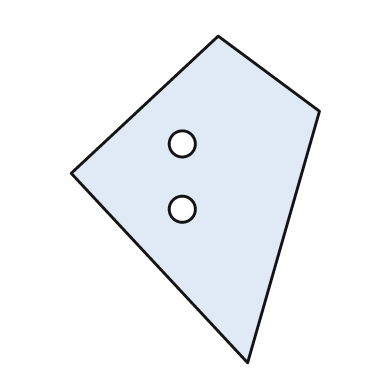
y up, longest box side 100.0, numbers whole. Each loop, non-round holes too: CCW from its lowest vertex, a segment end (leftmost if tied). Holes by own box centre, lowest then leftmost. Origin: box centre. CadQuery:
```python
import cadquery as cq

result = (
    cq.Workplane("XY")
    .moveTo(16.0, -50.0)
    .lineTo(38.0, 27.0)
    .lineTo(7.0, 50.0)
    .lineTo(-38.0, 8.0)
    .close()
    .moveTo(-4.0, -3.0)
    .circle(4.0)
    .moveTo(-4.0, 17.0)
    .circle(4.0)
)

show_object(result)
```